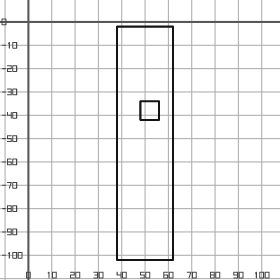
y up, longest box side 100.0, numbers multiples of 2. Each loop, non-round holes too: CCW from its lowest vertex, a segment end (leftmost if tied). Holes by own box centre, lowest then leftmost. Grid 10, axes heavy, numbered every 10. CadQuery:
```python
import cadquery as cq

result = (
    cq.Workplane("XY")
    .moveTo(38.0, -102.0)
    .lineTo(62.0, -102.0)
    .lineTo(62.0, -2.0)
    .lineTo(38.0, -2.0)
    .close()
    .moveTo(48.0, -42.0)
    .lineTo(56.0, -42.0)
    .lineTo(56.0, -34.0)
    .lineTo(48.0, -34.0)
    .close()
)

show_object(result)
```